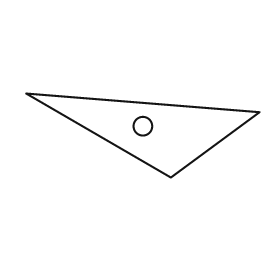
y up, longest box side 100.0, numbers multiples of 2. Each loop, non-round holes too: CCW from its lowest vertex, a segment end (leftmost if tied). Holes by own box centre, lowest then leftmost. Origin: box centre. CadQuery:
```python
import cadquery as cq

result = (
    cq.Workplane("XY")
    .moveTo(12.0, -18.0)
    .lineTo(50.0, 10.0)
    .lineTo(-50.0, 18.0)
    .close()
    .moveTo(0.0, 4.0)
    .circle(4.0)
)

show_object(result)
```